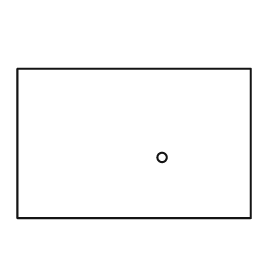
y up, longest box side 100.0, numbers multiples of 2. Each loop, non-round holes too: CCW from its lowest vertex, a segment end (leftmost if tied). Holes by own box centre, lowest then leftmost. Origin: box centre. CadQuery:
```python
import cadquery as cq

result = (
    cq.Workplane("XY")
    .moveTo(-50.0, -32.0)
    .lineTo(50.0, -32.0)
    .lineTo(50.0, 32.0)
    .lineTo(-50.0, 32.0)
    .close()
    .moveTo(12.0, -6.0)
    .circle(2.0)
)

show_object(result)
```